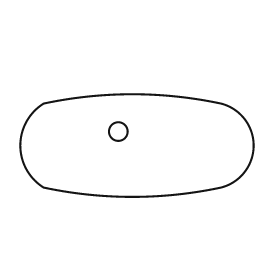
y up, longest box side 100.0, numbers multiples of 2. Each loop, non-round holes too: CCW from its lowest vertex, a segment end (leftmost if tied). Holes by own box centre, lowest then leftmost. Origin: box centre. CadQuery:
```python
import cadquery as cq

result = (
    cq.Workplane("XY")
    .moveTo(-40.0, -18.0)
    .threePointArc((-2.0, -22.0), (36.0, -18.0))
    .threePointArc((50.0, 0.0), (36.0, 18.0))
    .threePointArc((-2.0, 22.0), (-40.0, 18.0))
    .threePointArc((-50.0, 0.0), (-40.0, -18.0))
    .close()
    .moveTo(-8.0, 6.0)
    .circle(4.0)
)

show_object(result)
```